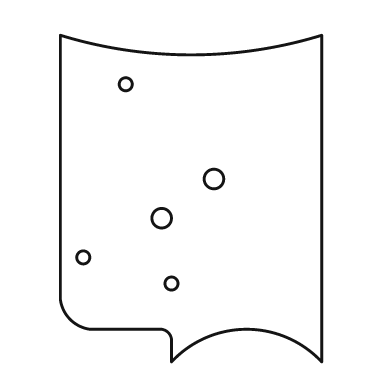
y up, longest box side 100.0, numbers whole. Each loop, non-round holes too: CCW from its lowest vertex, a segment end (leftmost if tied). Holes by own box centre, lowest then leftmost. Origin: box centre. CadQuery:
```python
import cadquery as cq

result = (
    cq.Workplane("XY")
    .moveTo(-6.0, -50.0)
    .threePointArc((17.0, -40.0), (40.0, -50.0))
    .lineTo(40.0, 50.0)
    .threePointArc((0.0, 44.0), (-40.0, 50.0))
    .lineTo(-40.0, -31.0)
    .threePointArc((-37.0, -37.0), (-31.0, -40.0))
    .lineTo(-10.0, -40.0)
    .threePointArc((-7.0, -41.0), (-6.0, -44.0))
    .close()
    .moveTo(-6.0, -26.0)
    .circle(2.0)
    .moveTo(-33.0, -18.0)
    .circle(2.0)
    .moveTo(-9.0, -6.0)
    .circle(3.0)
    .moveTo(7.0, 6.0)
    .circle(3.0)
    .moveTo(-20.0, 35.0)
    .circle(2.0)
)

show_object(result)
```